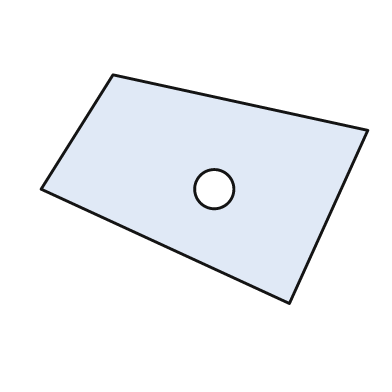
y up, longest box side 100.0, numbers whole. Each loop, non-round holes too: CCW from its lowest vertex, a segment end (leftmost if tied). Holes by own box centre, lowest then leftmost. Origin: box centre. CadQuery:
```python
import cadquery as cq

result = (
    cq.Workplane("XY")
    .moveTo(26.0, -35.0)
    .lineTo(50.0, 18.0)
    .lineTo(-28.0, 35.0)
    .lineTo(-50.0, 0.0)
    .close()
    .moveTo(3.0, 0.0)
    .circle(6.0)
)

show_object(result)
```